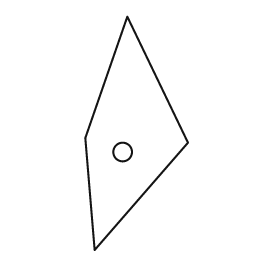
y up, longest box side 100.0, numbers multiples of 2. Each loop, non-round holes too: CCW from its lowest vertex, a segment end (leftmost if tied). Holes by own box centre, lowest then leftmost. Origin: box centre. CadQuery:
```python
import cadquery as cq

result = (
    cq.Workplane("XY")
    .moveTo(-18.0, -50.0)
    .lineTo(22.0, -4.0)
    .lineTo(-4.0, 50.0)
    .lineTo(-22.0, -2.0)
    .close()
    .moveTo(-6.0, -8.0)
    .circle(4.0)
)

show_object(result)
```